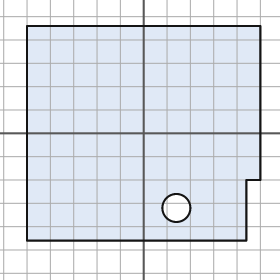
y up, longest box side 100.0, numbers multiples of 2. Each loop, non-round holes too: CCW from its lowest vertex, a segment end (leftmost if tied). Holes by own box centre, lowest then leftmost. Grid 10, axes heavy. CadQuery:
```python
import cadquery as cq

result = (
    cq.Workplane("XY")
    .moveTo(-50.0, -46.0)
    .lineTo(44.0, -46.0)
    .lineTo(44.0, -20.0)
    .lineTo(50.0, -20.0)
    .lineTo(50.0, 46.0)
    .lineTo(-50.0, 46.0)
    .close()
    .moveTo(14.0, -32.0)
    .circle(6.0)
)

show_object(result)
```